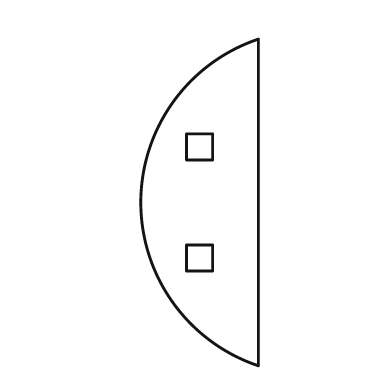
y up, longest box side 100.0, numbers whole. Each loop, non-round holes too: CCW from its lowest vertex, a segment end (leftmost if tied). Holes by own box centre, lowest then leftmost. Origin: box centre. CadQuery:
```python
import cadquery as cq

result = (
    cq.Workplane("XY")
    .moveTo(18.0, -50.0)
    .lineTo(18.0, 50.0)
    .threePointArc((-18.0, 0.0), (18.0, -50.0))
    .close()
    .moveTo(-4.0, -21.0)
    .lineTo(4.0, -21.0)
    .lineTo(4.0, -13.0)
    .lineTo(-4.0, -13.0)
    .close()
    .moveTo(-4.0, 13.0)
    .lineTo(4.0, 13.0)
    .lineTo(4.0, 21.0)
    .lineTo(-4.0, 21.0)
    .close()
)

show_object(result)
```